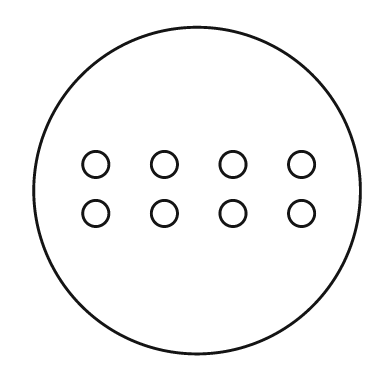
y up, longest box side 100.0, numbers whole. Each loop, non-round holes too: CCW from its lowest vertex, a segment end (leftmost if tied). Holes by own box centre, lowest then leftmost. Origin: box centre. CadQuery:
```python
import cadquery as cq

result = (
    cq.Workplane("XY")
    .moveTo(0.0, 0.0)
    .circle(50.0)
    .moveTo(-31.0, -7.0)
    .circle(4.0)
    .moveTo(-10.0, -7.0)
    .circle(4.0)
    .moveTo(11.0, -7.0)
    .circle(4.0)
    .moveTo(32.0, -7.0)
    .circle(4.0)
    .moveTo(-31.0, 8.0)
    .circle(4.0)
    .moveTo(-10.0, 8.0)
    .circle(4.0)
    .moveTo(11.0, 8.0)
    .circle(4.0)
    .moveTo(32.0, 8.0)
    .circle(4.0)
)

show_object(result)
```